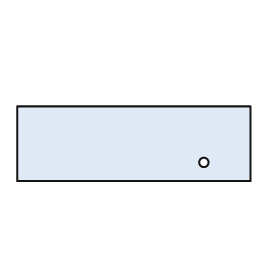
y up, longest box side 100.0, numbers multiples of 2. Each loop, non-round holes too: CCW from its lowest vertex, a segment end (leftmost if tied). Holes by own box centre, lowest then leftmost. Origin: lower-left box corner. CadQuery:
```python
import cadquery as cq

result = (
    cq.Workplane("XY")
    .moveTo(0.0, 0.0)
    .lineTo(100.0, 0.0)
    .lineTo(100.0, 32.0)
    .lineTo(0.0, 32.0)
    .close()
    .moveTo(80.0, 8.0)
    .circle(2.0)
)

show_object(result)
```